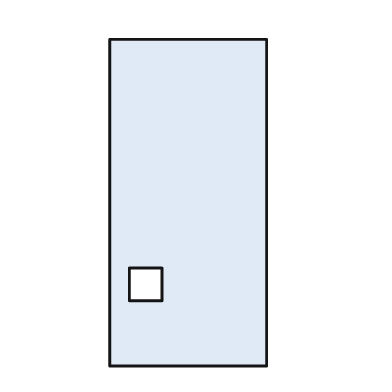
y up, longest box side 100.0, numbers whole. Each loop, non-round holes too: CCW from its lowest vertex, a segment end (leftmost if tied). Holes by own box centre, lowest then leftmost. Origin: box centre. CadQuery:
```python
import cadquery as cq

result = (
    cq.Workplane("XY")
    .moveTo(-24.0, -50.0)
    .lineTo(24.0, -50.0)
    .lineTo(24.0, 50.0)
    .lineTo(-24.0, 50.0)
    .close()
    .moveTo(-18.0, -30.0)
    .lineTo(-8.0, -30.0)
    .lineTo(-8.0, -20.0)
    .lineTo(-18.0, -20.0)
    .close()
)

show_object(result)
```